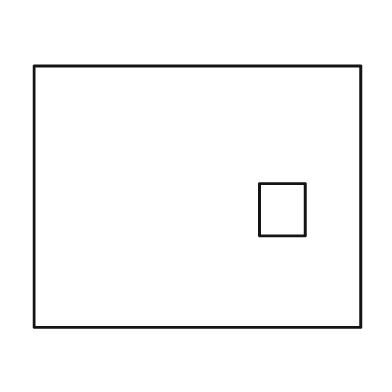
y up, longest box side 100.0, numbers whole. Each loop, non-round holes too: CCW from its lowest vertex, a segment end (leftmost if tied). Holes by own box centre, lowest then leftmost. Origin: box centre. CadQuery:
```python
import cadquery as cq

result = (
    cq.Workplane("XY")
    .moveTo(-50.0, -40.0)
    .lineTo(50.0, -40.0)
    .lineTo(50.0, 40.0)
    .lineTo(-50.0, 40.0)
    .close()
    .moveTo(19.0, -12.0)
    .lineTo(33.0, -12.0)
    .lineTo(33.0, 4.0)
    .lineTo(19.0, 4.0)
    .close()
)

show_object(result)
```